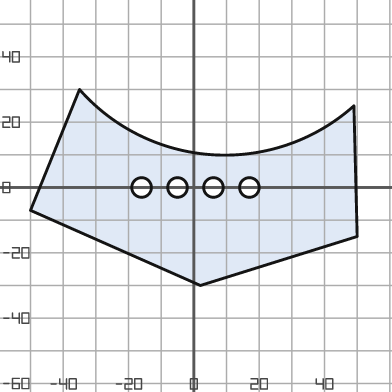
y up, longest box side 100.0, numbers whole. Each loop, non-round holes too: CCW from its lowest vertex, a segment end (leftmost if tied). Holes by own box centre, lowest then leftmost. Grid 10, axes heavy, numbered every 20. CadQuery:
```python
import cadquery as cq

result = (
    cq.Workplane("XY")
    .moveTo(2.0, -30.0)
    .lineTo(50.0, -15.0)
    .lineTo(49.0, 25.0)
    .threePointArc((6.0, 10.0), (-35.0, 30.0))
    .lineTo(-50.0, -7.0)
    .close()
    .moveTo(-16.0, 0.0)
    .circle(3.0)
    .moveTo(-5.0, 0.0)
    .circle(3.0)
    .moveTo(6.0, 0.0)
    .circle(3.0)
    .moveTo(17.0, 0.0)
    .circle(3.0)
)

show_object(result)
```